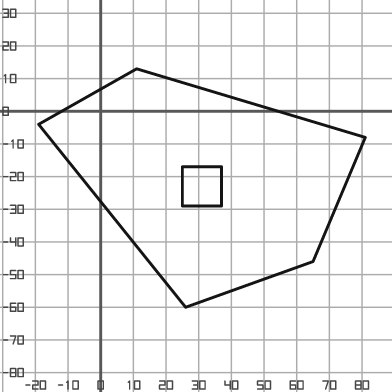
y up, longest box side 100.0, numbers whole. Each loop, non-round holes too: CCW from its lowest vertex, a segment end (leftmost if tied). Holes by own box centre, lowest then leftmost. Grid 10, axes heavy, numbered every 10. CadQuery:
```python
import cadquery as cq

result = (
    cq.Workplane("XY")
    .moveTo(26.0, -60.0)
    .lineTo(65.0, -46.0)
    .lineTo(81.0, -8.0)
    .lineTo(11.0, 13.0)
    .lineTo(-19.0, -4.0)
    .close()
    .moveTo(25.0, -29.0)
    .lineTo(37.0, -29.0)
    .lineTo(37.0, -17.0)
    .lineTo(25.0, -17.0)
    .close()
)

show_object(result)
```